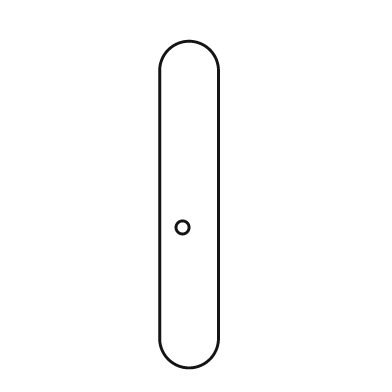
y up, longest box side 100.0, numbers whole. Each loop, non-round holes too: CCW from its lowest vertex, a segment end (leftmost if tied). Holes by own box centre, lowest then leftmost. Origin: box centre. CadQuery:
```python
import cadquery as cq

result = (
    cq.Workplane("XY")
    .moveTo(-9.0, -41.0)
    .threePointArc((0.0, -50.0), (9.0, -41.0))
    .lineTo(9.0, 41.0)
    .threePointArc((0.0, 50.0), (-9.0, 41.0))
    .close()
    .moveTo(-2.0, -7.0)
    .circle(2.0)
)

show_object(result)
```